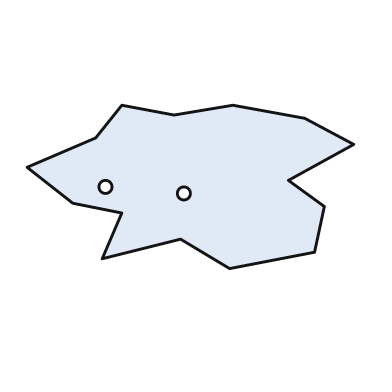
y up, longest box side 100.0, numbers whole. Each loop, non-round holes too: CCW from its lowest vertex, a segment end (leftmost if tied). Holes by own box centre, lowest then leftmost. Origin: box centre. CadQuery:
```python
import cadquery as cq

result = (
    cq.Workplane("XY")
    .moveTo(12.0, -25.0)
    .lineTo(38.0, -20.0)
    .lineTo(41.0, -6.0)
    .lineTo(30.0, 2.0)
    .lineTo(50.0, 13.0)
    .lineTo(35.0, 21.0)
    .lineTo(13.0, 25.0)
    .lineTo(-5.0, 22.0)
    .lineTo(-21.0, 25.0)
    .lineTo(-29.0, 15.0)
    .lineTo(-50.0, 6.0)
    .lineTo(-36.0, -5.0)
    .lineTo(-21.0, -8.0)
    .lineTo(-27.0, -22.0)
    .lineTo(-3.0, -16.0)
    .close()
    .moveTo(-2.0, -2.0)
    .circle(2.0)
    .moveTo(-26.0, 0.0)
    .circle(2.0)
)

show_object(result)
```